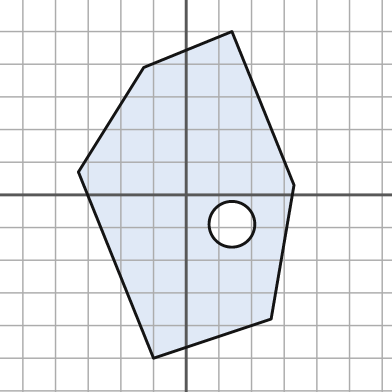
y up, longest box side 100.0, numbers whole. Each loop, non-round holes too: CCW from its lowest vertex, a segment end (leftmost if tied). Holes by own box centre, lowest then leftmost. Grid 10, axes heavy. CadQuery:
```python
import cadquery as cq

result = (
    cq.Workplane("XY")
    .moveTo(-10.0, -50.0)
    .lineTo(26.0, -38.0)
    .lineTo(33.0, 3.0)
    .lineTo(14.0, 50.0)
    .lineTo(-13.0, 39.0)
    .lineTo(-33.0, 7.0)
    .close()
    .moveTo(14.0, -9.0)
    .circle(7.0)
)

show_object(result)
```